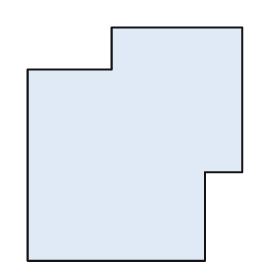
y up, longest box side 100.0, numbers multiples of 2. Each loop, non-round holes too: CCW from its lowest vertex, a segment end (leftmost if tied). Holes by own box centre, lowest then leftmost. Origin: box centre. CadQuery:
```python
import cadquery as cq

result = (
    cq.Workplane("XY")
    .moveTo(-46.0, -50.0)
    .lineTo(30.0, -50.0)
    .lineTo(30.0, -12.0)
    .lineTo(46.0, -12.0)
    .lineTo(46.0, 50.0)
    .lineTo(-10.0, 50.0)
    .lineTo(-10.0, 32.0)
    .lineTo(-46.0, 32.0)
    .close()
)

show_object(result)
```